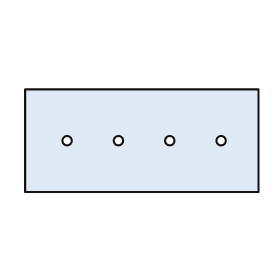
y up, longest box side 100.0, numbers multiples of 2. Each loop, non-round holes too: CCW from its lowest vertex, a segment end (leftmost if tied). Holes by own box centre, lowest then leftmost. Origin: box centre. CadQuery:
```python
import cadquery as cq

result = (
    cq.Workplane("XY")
    .moveTo(-50.0, -22.0)
    .lineTo(50.0, -22.0)
    .lineTo(50.0, 22.0)
    .lineTo(-50.0, 22.0)
    .close()
    .moveTo(-32.0, 0.0)
    .circle(2.0)
    .moveTo(-10.0, 0.0)
    .circle(2.0)
    .moveTo(12.0, 0.0)
    .circle(2.0)
    .moveTo(34.0, 0.0)
    .circle(2.0)
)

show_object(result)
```